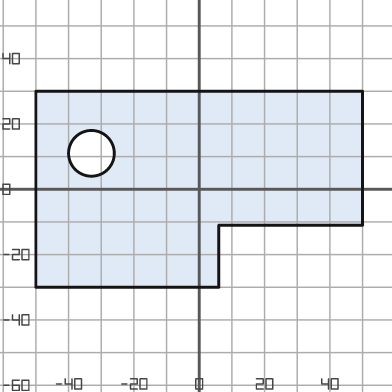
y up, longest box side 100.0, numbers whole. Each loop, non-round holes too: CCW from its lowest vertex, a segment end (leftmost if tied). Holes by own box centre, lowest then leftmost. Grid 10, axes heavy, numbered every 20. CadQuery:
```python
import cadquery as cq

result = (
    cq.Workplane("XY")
    .moveTo(-50.0, -30.0)
    .lineTo(6.0, -30.0)
    .lineTo(6.0, -11.0)
    .lineTo(50.0, -11.0)
    .lineTo(50.0, 30.0)
    .lineTo(-50.0, 30.0)
    .close()
    .moveTo(-33.0, 11.0)
    .circle(7.0)
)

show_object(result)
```